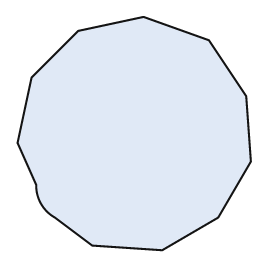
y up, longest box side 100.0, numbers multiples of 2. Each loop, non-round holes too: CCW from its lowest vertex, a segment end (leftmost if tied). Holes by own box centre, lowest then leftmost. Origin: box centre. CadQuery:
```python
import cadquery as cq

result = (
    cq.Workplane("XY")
    .moveTo(12.0, -50.0)
    .lineTo(36.0, -36.0)
    .lineTo(50.0, -12.0)
    .lineTo(48.0, 16.0)
    .lineTo(32.0, 40.0)
    .lineTo(4.0, 50.0)
    .lineTo(-24.0, 44.0)
    .lineTo(-44.0, 24.0)
    .lineTo(-50.0, -4.0)
    .lineTo(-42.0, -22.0)
    .threePointArc((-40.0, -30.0), (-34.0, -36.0))
    .lineTo(-18.0, -48.0)
    .close()
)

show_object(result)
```